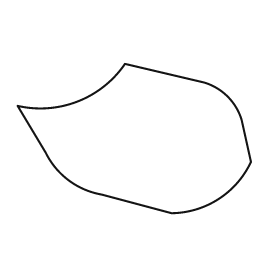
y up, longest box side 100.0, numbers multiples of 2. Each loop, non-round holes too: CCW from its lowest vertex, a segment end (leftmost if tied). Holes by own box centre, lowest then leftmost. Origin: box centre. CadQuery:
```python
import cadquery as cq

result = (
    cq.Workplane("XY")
    .moveTo(16.0, -32.0)
    .threePointArc((36.0, -26.0), (50.0, -10.0))
    .lineTo(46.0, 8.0)
    .threePointArc((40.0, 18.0), (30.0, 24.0))
    .lineTo(-4.0, 32.0)
    .threePointArc((-24.0, 16.0), (-50.0, 14.0))
    .lineTo(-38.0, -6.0)
    .threePointArc((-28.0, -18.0), (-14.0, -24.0))
    .close()
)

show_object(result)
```